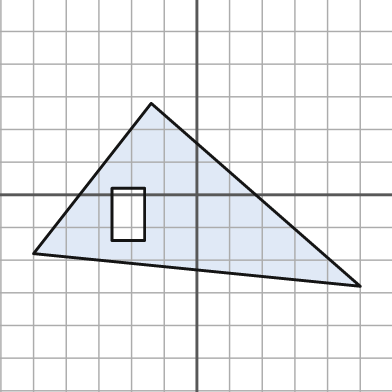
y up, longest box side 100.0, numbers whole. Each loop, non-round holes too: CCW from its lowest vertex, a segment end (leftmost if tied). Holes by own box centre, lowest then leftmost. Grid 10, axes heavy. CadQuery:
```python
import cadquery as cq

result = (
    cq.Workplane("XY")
    .moveTo(50.0, -28.0)
    .lineTo(-14.0, 28.0)
    .lineTo(-50.0, -18.0)
    .close()
    .moveTo(-26.0, -14.0)
    .lineTo(-16.0, -14.0)
    .lineTo(-16.0, 2.0)
    .lineTo(-26.0, 2.0)
    .close()
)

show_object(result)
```